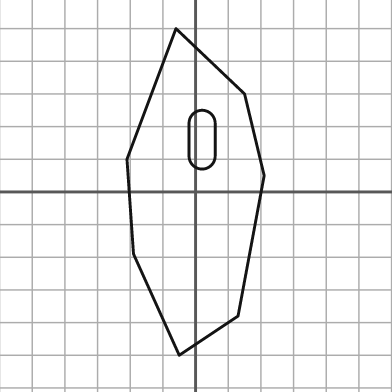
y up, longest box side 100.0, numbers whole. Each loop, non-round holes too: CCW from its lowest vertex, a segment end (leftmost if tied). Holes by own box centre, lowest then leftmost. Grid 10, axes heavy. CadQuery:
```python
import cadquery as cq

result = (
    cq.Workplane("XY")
    .moveTo(-5.0, -50.0)
    .lineTo(13.0, -38.0)
    .lineTo(21.0, 5.0)
    .lineTo(15.0, 30.0)
    .lineTo(-6.0, 50.0)
    .lineTo(-21.0, 10.0)
    .lineTo(-19.0, -19.0)
    .close()
    .moveTo(-2.0, 11.0)
    .threePointArc((2.0, 7.0), (6.0, 11.0))
    .lineTo(6.0, 21.0)
    .threePointArc((2.0, 25.0), (-2.0, 21.0))
    .close()
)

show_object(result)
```